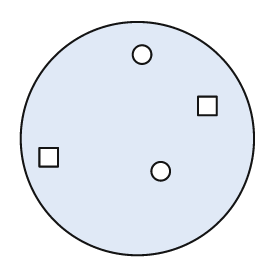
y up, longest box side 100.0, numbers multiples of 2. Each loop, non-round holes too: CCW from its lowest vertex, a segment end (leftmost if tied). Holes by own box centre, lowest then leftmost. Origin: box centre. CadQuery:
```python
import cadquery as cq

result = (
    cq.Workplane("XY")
    .moveTo(0.0, 0.0)
    .circle(50.0)
    .moveTo(10.0, -14.0)
    .circle(4.0)
    .moveTo(-42.0, -12.0)
    .lineTo(-34.0, -12.0)
    .lineTo(-34.0, -4.0)
    .lineTo(-42.0, -4.0)
    .close()
    .moveTo(26.0, 10.0)
    .lineTo(34.0, 10.0)
    .lineTo(34.0, 18.0)
    .lineTo(26.0, 18.0)
    .close()
    .moveTo(2.0, 36.0)
    .circle(4.0)
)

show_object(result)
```